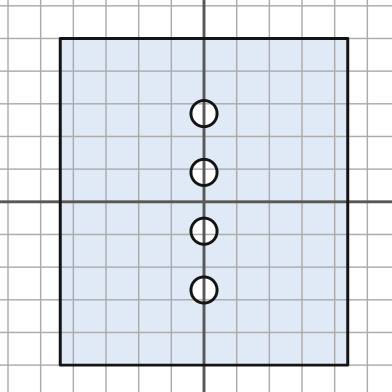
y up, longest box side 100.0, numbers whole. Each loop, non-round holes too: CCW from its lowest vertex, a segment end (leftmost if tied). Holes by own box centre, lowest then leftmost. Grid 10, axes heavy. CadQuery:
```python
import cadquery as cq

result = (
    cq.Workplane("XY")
    .moveTo(-44.0, -50.0)
    .lineTo(44.0, -50.0)
    .lineTo(44.0, 50.0)
    .lineTo(-44.0, 50.0)
    .close()
    .moveTo(0.0, -27.0)
    .circle(4.0)
    .moveTo(0.0, -9.0)
    .circle(4.0)
    .moveTo(0.0, 9.0)
    .circle(4.0)
    .moveTo(0.0, 27.0)
    .circle(4.0)
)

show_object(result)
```